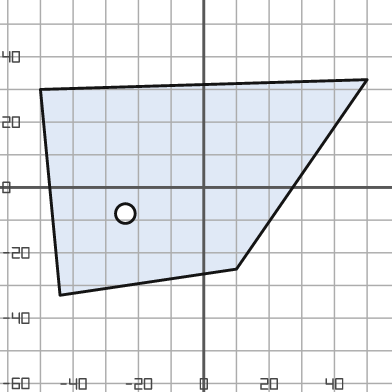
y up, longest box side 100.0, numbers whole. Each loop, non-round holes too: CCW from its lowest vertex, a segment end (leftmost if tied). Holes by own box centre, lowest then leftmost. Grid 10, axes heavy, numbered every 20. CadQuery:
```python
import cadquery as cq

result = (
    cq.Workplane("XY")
    .moveTo(-44.0, -33.0)
    .lineTo(10.0, -25.0)
    .lineTo(50.0, 33.0)
    .lineTo(-50.0, 30.0)
    .close()
    .moveTo(-24.0, -8.0)
    .circle(3.0)
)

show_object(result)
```